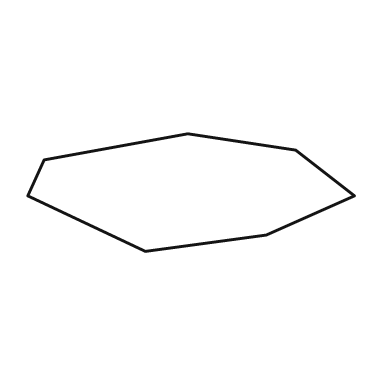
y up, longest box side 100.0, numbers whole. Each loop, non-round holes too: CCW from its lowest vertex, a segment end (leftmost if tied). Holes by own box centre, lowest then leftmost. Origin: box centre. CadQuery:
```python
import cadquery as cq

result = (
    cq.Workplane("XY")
    .moveTo(-14.0, -18.0)
    .lineTo(23.0, -13.0)
    .lineTo(50.0, -1.0)
    .lineTo(32.0, 13.0)
    .lineTo(-1.0, 18.0)
    .lineTo(-45.0, 10.0)
    .lineTo(-50.0, -1.0)
    .close()
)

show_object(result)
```